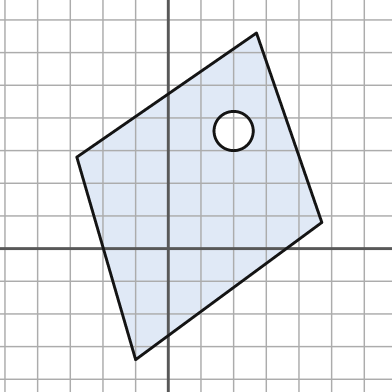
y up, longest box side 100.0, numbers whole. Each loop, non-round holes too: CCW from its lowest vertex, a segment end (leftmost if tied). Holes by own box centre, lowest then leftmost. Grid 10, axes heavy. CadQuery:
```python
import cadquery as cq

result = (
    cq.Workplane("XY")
    .moveTo(-10.0, -34.0)
    .lineTo(47.0, 8.0)
    .lineTo(27.0, 66.0)
    .lineTo(-28.0, 28.0)
    .close()
    .moveTo(20.0, 36.0)
    .circle(6.0)
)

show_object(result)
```